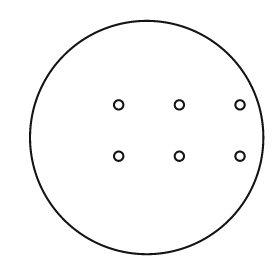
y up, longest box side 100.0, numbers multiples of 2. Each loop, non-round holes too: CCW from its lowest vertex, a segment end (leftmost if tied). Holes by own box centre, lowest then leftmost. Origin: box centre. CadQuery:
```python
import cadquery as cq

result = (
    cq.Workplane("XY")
    .moveTo(0.0, 0.0)
    .circle(50.0)
    .moveTo(-12.0, -8.0)
    .circle(2.0)
    .moveTo(14.0, -8.0)
    .circle(2.0)
    .moveTo(40.0, -8.0)
    .circle(2.0)
    .moveTo(-12.0, 14.0)
    .circle(2.0)
    .moveTo(14.0, 14.0)
    .circle(2.0)
    .moveTo(40.0, 14.0)
    .circle(2.0)
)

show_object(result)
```